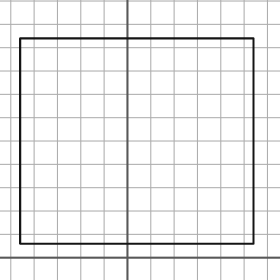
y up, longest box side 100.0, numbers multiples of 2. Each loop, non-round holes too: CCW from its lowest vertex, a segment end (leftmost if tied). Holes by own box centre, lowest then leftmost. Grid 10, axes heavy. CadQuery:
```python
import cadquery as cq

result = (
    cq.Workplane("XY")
    .moveTo(-46.0, 6.0)
    .lineTo(54.0, 6.0)
    .lineTo(54.0, 94.0)
    .lineTo(-46.0, 94.0)
    .close()
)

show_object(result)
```